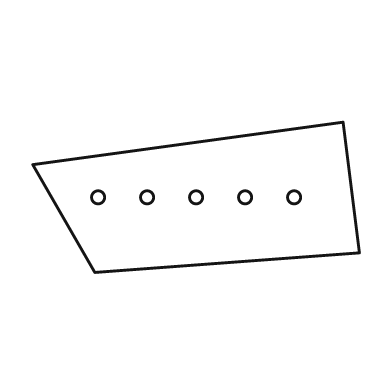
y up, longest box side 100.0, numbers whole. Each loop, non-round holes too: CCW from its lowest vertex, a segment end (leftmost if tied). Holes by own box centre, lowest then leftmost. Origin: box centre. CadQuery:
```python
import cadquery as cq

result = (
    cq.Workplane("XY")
    .moveTo(-31.0, -23.0)
    .lineTo(50.0, -17.0)
    .lineTo(45.0, 23.0)
    .lineTo(-50.0, 10.0)
    .close()
    .moveTo(-30.0, 0.0)
    .circle(2.0)
    .moveTo(-15.0, 0.0)
    .circle(2.0)
    .moveTo(0.0, 0.0)
    .circle(2.0)
    .moveTo(15.0, 0.0)
    .circle(2.0)
    .moveTo(30.0, 0.0)
    .circle(2.0)
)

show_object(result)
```